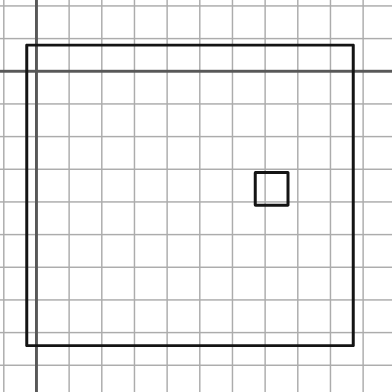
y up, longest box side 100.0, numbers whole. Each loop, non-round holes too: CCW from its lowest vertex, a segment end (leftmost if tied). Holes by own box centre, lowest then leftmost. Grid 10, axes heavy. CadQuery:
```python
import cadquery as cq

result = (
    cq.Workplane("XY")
    .moveTo(-3.0, -84.0)
    .lineTo(97.0, -84.0)
    .lineTo(97.0, 8.0)
    .lineTo(-3.0, 8.0)
    .close()
    .moveTo(67.0, -41.0)
    .lineTo(77.0, -41.0)
    .lineTo(77.0, -31.0)
    .lineTo(67.0, -31.0)
    .close()
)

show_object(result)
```